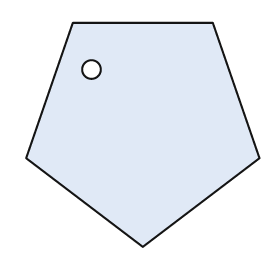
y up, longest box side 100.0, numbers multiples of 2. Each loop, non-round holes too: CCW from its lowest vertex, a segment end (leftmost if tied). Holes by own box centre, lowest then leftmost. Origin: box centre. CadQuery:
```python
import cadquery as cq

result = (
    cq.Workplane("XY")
    .moveTo(0.0, -48.0)
    .lineTo(50.0, -10.0)
    .lineTo(30.0, 48.0)
    .lineTo(-30.0, 48.0)
    .lineTo(-50.0, -10.0)
    .close()
    .moveTo(-22.0, 28.0)
    .circle(4.0)
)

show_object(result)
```